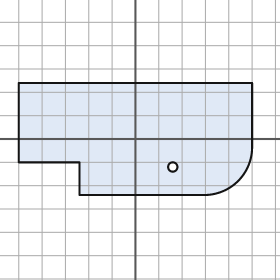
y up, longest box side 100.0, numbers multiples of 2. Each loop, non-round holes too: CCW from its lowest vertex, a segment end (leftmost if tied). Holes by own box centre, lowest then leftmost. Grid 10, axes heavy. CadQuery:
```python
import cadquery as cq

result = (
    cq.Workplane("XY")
    .moveTo(-24.0, -24.0)
    .lineTo(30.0, -24.0)
    .threePointArc((44.0, -18.0), (50.0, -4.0))
    .lineTo(50.0, 24.0)
    .lineTo(-50.0, 24.0)
    .lineTo(-50.0, -10.0)
    .lineTo(-24.0, -10.0)
    .close()
    .moveTo(16.0, -12.0)
    .circle(2.0)
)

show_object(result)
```